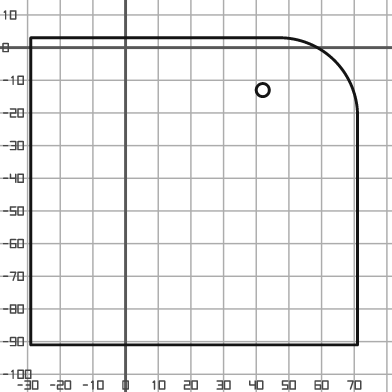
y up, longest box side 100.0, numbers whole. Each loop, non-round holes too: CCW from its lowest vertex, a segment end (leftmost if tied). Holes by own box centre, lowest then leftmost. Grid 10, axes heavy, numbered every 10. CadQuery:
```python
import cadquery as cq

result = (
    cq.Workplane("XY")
    .moveTo(-29.0, -91.0)
    .lineTo(71.0, -91.0)
    .lineTo(71.0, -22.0)
    .threePointArc((64.0, -4.0), (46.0, 3.0))
    .lineTo(-29.0, 3.0)
    .close()
    .moveTo(42.0, -13.0)
    .circle(2.0)
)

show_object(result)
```